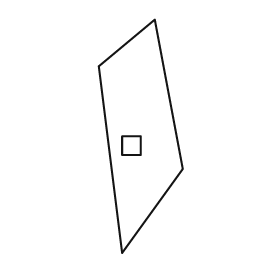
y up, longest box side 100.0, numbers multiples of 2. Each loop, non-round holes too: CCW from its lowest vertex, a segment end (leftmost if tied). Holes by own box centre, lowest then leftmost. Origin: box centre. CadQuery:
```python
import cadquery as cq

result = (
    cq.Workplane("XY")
    .moveTo(-8.0, -50.0)
    .lineTo(18.0, -14.0)
    .lineTo(6.0, 50.0)
    .lineTo(-18.0, 30.0)
    .close()
    .moveTo(-8.0, -8.0)
    .lineTo(0.0, -8.0)
    .lineTo(0.0, 0.0)
    .lineTo(-8.0, 0.0)
    .close()
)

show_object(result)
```